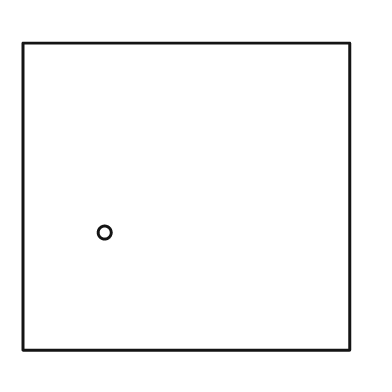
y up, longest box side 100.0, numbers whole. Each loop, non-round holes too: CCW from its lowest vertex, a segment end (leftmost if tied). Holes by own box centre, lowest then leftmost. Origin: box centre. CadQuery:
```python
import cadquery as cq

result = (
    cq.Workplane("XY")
    .moveTo(-50.0, -47.0)
    .lineTo(50.0, -47.0)
    .lineTo(50.0, 47.0)
    .lineTo(-50.0, 47.0)
    .close()
    .moveTo(-25.0, -11.0)
    .circle(2.0)
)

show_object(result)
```